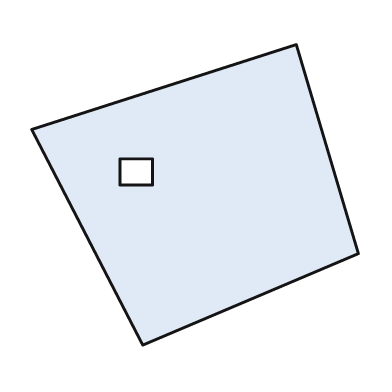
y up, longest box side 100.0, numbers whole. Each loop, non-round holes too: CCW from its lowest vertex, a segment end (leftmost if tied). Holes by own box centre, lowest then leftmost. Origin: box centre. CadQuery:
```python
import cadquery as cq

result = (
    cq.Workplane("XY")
    .moveTo(-16.0, -46.0)
    .lineTo(50.0, -18.0)
    .lineTo(31.0, 46.0)
    .lineTo(-50.0, 20.0)
    .close()
    .moveTo(-23.0, 3.0)
    .lineTo(-13.0, 3.0)
    .lineTo(-13.0, 11.0)
    .lineTo(-23.0, 11.0)
    .close()
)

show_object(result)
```